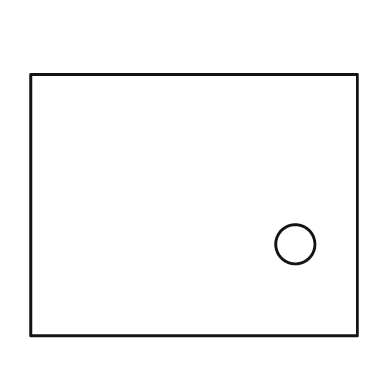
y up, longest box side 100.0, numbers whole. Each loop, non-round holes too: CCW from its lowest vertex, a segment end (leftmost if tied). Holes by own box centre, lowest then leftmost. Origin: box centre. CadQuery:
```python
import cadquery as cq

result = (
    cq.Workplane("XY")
    .moveTo(-50.0, -40.0)
    .lineTo(50.0, -40.0)
    .lineTo(50.0, 40.0)
    .lineTo(-50.0, 40.0)
    .close()
    .moveTo(31.0, -12.0)
    .circle(6.0)
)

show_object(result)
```